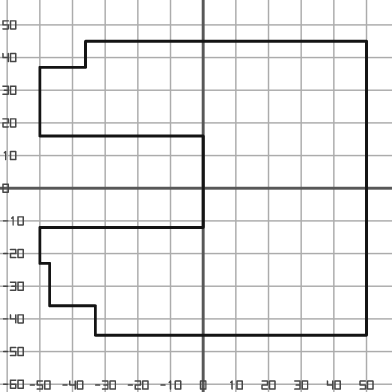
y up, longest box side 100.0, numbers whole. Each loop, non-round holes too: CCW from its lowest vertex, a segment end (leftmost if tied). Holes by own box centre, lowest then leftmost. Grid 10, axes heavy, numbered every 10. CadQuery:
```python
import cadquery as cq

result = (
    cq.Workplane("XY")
    .moveTo(-33.0, -45.0)
    .lineTo(50.0, -45.0)
    .lineTo(50.0, 45.0)
    .lineTo(-36.0, 45.0)
    .lineTo(-36.0, 37.0)
    .lineTo(-50.0, 37.0)
    .lineTo(-50.0, 16.0)
    .lineTo(0.0, 16.0)
    .lineTo(0.0, -12.0)
    .lineTo(-50.0, -12.0)
    .lineTo(-50.0, -23.0)
    .lineTo(-47.0, -23.0)
    .lineTo(-47.0, -36.0)
    .lineTo(-33.0, -36.0)
    .close()
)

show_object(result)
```